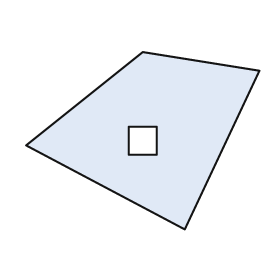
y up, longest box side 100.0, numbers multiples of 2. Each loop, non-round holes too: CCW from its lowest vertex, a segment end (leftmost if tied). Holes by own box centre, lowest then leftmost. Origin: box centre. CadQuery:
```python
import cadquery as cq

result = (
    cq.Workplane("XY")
    .moveTo(18.0, -38.0)
    .lineTo(50.0, 30.0)
    .lineTo(0.0, 38.0)
    .lineTo(-50.0, -2.0)
    .close()
    .moveTo(-6.0, -6.0)
    .lineTo(6.0, -6.0)
    .lineTo(6.0, 6.0)
    .lineTo(-6.0, 6.0)
    .close()
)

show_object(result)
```